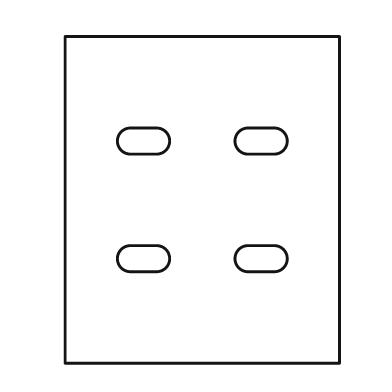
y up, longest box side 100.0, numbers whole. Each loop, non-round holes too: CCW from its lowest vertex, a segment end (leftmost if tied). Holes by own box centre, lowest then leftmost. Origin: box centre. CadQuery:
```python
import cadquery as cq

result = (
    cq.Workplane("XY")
    .moveTo(-42.0, -50.0)
    .lineTo(42.0, -50.0)
    .lineTo(42.0, 50.0)
    .lineTo(-42.0, 50.0)
    .close()
    .moveTo(-22.0, -22.0)
    .lineTo(-14.0, -22.0)
    .threePointArc((-10.0, -18.0), (-14.0, -14.0))
    .lineTo(-22.0, -14.0)
    .threePointArc((-26.0, -18.0), (-22.0, -22.0))
    .close()
    .moveTo(14.0, -22.0)
    .lineTo(22.0, -22.0)
    .threePointArc((26.0, -18.0), (22.0, -14.0))
    .lineTo(14.0, -14.0)
    .threePointArc((10.0, -18.0), (14.0, -22.0))
    .close()
    .moveTo(-22.0, 14.0)
    .lineTo(-14.0, 14.0)
    .threePointArc((-10.0, 18.0), (-14.0, 22.0))
    .lineTo(-22.0, 22.0)
    .threePointArc((-26.0, 18.0), (-22.0, 14.0))
    .close()
    .moveTo(14.0, 14.0)
    .lineTo(22.0, 14.0)
    .threePointArc((26.0, 18.0), (22.0, 22.0))
    .lineTo(14.0, 22.0)
    .threePointArc((10.0, 18.0), (14.0, 14.0))
    .close()
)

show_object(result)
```